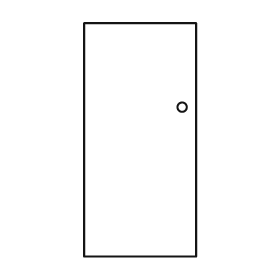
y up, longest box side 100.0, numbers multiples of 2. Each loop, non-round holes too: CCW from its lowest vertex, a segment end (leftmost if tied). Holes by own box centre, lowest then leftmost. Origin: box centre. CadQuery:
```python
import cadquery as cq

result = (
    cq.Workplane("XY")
    .moveTo(-24.0, -50.0)
    .lineTo(24.0, -50.0)
    .lineTo(24.0, 50.0)
    .lineTo(-24.0, 50.0)
    .close()
    .moveTo(18.0, 14.0)
    .circle(2.0)
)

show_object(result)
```